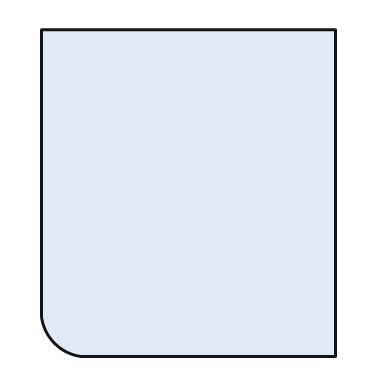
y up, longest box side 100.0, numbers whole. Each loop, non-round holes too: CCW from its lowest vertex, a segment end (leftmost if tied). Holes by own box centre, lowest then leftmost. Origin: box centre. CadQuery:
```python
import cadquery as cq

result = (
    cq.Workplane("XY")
    .moveTo(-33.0, -50.0)
    .lineTo(45.0, -50.0)
    .lineTo(45.0, 50.0)
    .lineTo(-45.0, 50.0)
    .lineTo(-45.0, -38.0)
    .threePointArc((-41.0, -46.0), (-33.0, -50.0))
    .close()
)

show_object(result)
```